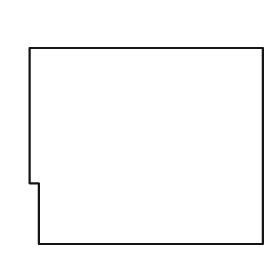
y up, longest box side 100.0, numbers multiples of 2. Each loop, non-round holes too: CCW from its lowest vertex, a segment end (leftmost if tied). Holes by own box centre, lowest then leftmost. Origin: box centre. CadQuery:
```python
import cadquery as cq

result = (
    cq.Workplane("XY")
    .moveTo(-46.0, -42.0)
    .lineTo(50.0, -42.0)
    .lineTo(50.0, 42.0)
    .lineTo(-50.0, 42.0)
    .lineTo(-50.0, -16.0)
    .lineTo(-46.0, -16.0)
    .close()
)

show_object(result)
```